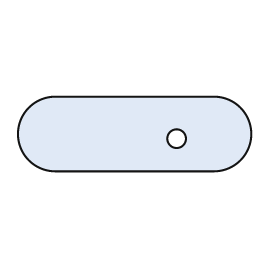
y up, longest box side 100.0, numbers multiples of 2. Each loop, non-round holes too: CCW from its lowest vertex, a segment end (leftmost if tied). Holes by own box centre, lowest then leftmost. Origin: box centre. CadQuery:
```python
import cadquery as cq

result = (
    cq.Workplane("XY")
    .moveTo(-34.0, -16.0)
    .lineTo(34.0, -16.0)
    .threePointArc((50.0, 0.0), (34.0, 16.0))
    .lineTo(-34.0, 16.0)
    .threePointArc((-50.0, 0.0), (-34.0, -16.0))
    .close()
    .moveTo(18.0, -2.0)
    .circle(4.0)
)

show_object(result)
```